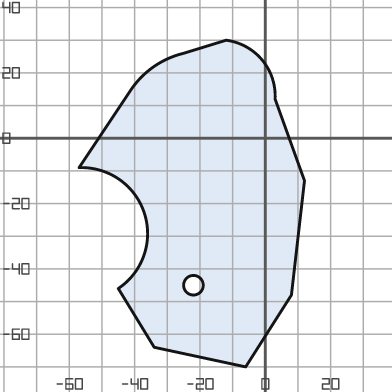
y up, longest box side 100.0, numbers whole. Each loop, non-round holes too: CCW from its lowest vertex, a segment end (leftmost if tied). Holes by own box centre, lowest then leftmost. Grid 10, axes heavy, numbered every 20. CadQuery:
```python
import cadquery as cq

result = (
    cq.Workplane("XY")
    .moveTo(-6.0, -70.0)
    .lineTo(8.0, -48.0)
    .lineTo(12.0, -13.0)
    .lineTo(3.0, 12.0)
    .threePointArc((-1.0, 24.0), (-12.0, 30.0))
    .lineTo(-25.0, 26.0)
    .threePointArc((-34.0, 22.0), (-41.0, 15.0))
    .lineTo(-57.0, -9.0)
    .threePointArc((-37.0, -23.0), (-45.0, -46.0))
    .lineTo(-34.0, -64.0)
    .close()
    .moveTo(-22.0, -45.0)
    .circle(3.0)
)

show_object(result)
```